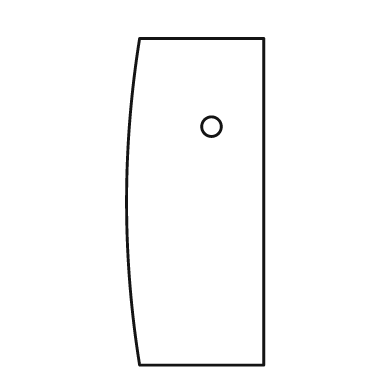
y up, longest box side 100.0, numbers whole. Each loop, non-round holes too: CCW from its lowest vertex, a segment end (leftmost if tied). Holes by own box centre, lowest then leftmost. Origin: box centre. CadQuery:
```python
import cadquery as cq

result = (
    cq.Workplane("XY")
    .moveTo(-17.0, -50.0)
    .lineTo(21.0, -50.0)
    .lineTo(21.0, 50.0)
    .lineTo(-17.0, 50.0)
    .threePointArc((-21.0, 0.0), (-17.0, -50.0))
    .close()
    .moveTo(5.0, 23.0)
    .circle(3.0)
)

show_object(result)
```